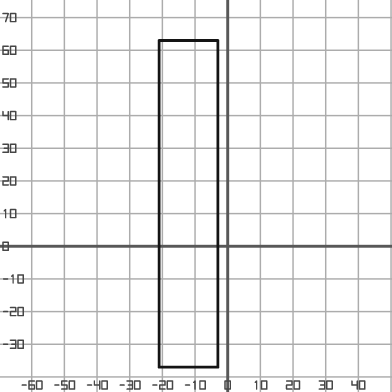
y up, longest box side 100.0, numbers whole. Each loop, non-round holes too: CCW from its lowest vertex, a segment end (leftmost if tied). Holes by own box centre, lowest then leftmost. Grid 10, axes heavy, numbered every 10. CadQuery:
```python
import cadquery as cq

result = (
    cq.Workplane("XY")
    .moveTo(-21.0, -37.0)
    .lineTo(-3.0, -37.0)
    .lineTo(-3.0, 63.0)
    .lineTo(-21.0, 63.0)
    .close()
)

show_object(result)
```